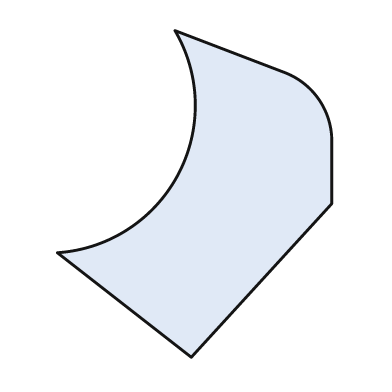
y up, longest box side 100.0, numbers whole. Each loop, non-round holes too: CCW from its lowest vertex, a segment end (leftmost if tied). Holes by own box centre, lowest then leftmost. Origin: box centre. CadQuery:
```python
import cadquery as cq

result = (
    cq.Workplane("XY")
    .moveTo(-1.0, -50.0)
    .lineTo(42.0, -3.0)
    .lineTo(42.0, 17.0)
    .threePointArc((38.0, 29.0), (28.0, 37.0))
    .lineTo(-6.0, 50.0)
    .threePointArc((-5.0, 6.0), (-42.0, -18.0))
    .close()
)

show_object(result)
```